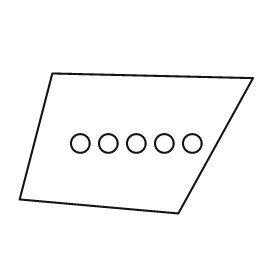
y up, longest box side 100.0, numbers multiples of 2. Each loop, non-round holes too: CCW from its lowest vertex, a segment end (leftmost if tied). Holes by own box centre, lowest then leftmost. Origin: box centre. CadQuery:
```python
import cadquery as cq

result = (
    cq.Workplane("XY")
    .moveTo(18.0, -30.0)
    .lineTo(50.0, 28.0)
    .lineTo(-36.0, 30.0)
    .lineTo(-50.0, -24.0)
    .close()
    .moveTo(-24.0, 0.0)
    .circle(4.0)
    .moveTo(-12.0, 0.0)
    .circle(4.0)
    .moveTo(0.0, 0.0)
    .circle(4.0)
    .moveTo(12.0, 0.0)
    .circle(4.0)
    .moveTo(24.0, 0.0)
    .circle(4.0)
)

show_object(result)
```